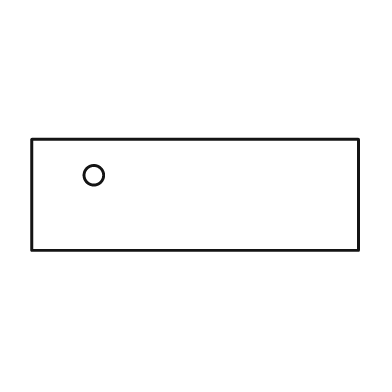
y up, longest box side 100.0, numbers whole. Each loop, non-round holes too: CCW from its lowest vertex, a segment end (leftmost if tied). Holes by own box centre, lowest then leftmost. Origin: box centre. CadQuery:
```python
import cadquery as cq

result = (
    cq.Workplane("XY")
    .moveTo(-50.0, -17.0)
    .lineTo(50.0, -17.0)
    .lineTo(50.0, 17.0)
    .lineTo(-50.0, 17.0)
    .close()
    .moveTo(-31.0, 6.0)
    .circle(3.0)
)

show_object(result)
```